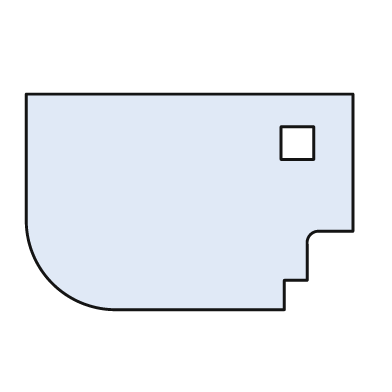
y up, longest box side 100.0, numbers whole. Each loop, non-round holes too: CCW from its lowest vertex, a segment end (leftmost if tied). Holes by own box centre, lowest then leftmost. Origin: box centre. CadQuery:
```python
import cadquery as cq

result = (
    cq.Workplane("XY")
    .moveTo(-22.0, -33.0)
    .lineTo(29.0, -33.0)
    .lineTo(29.0, -24.0)
    .lineTo(36.0, -24.0)
    .lineTo(36.0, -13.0)
    .threePointArc((37.0, -10.0), (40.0, -9.0))
    .lineTo(50.0, -9.0)
    .lineTo(50.0, 33.0)
    .lineTo(-50.0, 33.0)
    .lineTo(-50.0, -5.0)
    .threePointArc((-42.0, -25.0), (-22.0, -33.0))
    .close()
    .moveTo(28.0, 13.0)
    .lineTo(38.0, 13.0)
    .lineTo(38.0, 23.0)
    .lineTo(28.0, 23.0)
    .close()
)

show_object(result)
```